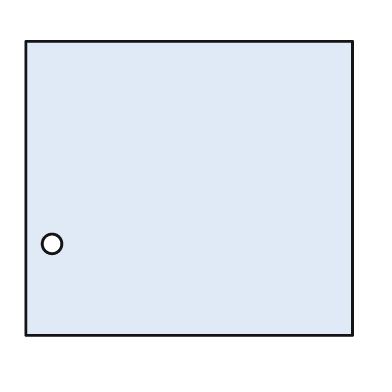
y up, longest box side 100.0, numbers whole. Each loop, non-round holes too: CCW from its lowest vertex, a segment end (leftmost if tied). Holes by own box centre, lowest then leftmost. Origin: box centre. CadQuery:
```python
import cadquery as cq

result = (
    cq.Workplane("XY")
    .moveTo(-50.0, -45.0)
    .lineTo(50.0, -45.0)
    .lineTo(50.0, 45.0)
    .lineTo(-50.0, 45.0)
    .close()
    .moveTo(-42.0, -17.0)
    .circle(3.0)
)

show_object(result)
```